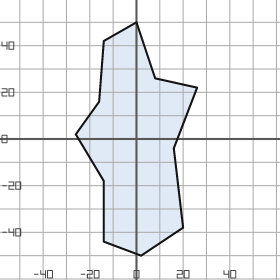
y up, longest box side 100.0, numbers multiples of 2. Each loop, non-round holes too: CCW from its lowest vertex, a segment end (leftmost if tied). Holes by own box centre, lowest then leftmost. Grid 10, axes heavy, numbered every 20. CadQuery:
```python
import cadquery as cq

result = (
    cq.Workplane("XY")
    .moveTo(2.0, -50.0)
    .lineTo(20.0, -38.0)
    .lineTo(16.0, -4.0)
    .lineTo(26.0, 22.0)
    .lineTo(8.0, 26.0)
    .lineTo(0.0, 50.0)
    .lineTo(-14.0, 42.0)
    .lineTo(-16.0, 16.0)
    .lineTo(-26.0, 2.0)
    .lineTo(-14.0, -18.0)
    .lineTo(-14.0, -44.0)
    .close()
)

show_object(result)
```